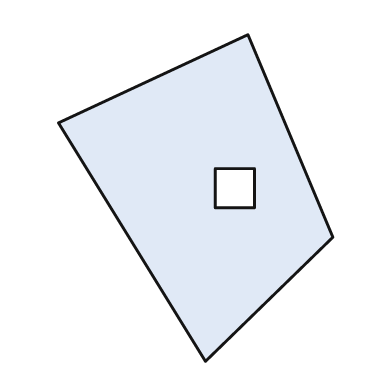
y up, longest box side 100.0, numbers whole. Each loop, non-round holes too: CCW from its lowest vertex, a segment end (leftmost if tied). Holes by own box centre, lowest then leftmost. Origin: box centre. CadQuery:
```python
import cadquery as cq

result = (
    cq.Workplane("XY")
    .moveTo(3.0, -50.0)
    .lineTo(42.0, -12.0)
    .lineTo(16.0, 50.0)
    .lineTo(-42.0, 23.0)
    .close()
    .moveTo(6.0, -3.0)
    .lineTo(18.0, -3.0)
    .lineTo(18.0, 9.0)
    .lineTo(6.0, 9.0)
    .close()
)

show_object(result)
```